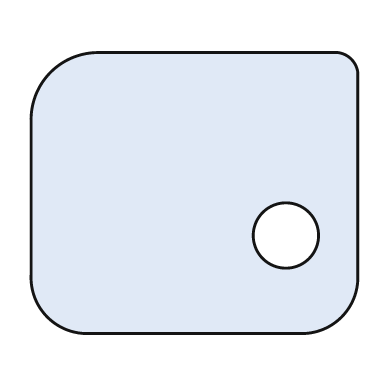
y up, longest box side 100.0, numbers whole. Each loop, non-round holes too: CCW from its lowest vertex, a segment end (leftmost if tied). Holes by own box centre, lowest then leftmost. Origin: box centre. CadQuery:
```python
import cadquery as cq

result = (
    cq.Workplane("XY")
    .moveTo(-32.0, -43.0)
    .lineTo(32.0, -43.0)
    .threePointArc((45.0, -38.0), (50.0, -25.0))
    .lineTo(50.0, 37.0)
    .threePointArc((48.0, 41.0), (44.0, 43.0))
    .lineTo(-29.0, 43.0)
    .threePointArc((-44.0, 37.0), (-50.0, 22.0))
    .lineTo(-50.0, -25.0)
    .threePointArc((-45.0, -38.0), (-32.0, -43.0))
    .close()
    .moveTo(28.0, -13.0)
    .circle(10.0)
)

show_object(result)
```